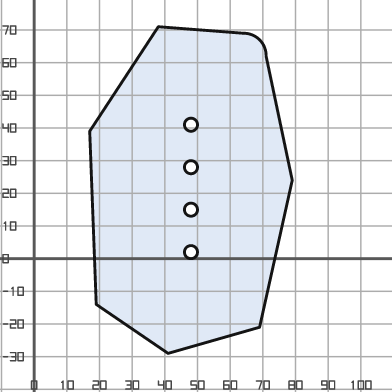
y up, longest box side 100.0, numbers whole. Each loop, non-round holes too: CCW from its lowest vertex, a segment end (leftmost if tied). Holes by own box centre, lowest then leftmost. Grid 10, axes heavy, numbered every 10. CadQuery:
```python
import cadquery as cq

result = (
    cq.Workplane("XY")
    .moveTo(41.0, -29.0)
    .lineTo(69.0, -21.0)
    .lineTo(79.0, 24.0)
    .lineTo(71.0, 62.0)
    .threePointArc((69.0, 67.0), (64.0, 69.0))
    .lineTo(38.0, 71.0)
    .lineTo(17.0, 39.0)
    .lineTo(19.0, -14.0)
    .close()
    .moveTo(48.0, 2.0)
    .circle(2.0)
    .moveTo(48.0, 15.0)
    .circle(2.0)
    .moveTo(48.0, 28.0)
    .circle(2.0)
    .moveTo(48.0, 41.0)
    .circle(2.0)
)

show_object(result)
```